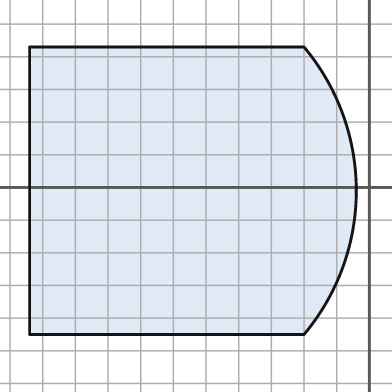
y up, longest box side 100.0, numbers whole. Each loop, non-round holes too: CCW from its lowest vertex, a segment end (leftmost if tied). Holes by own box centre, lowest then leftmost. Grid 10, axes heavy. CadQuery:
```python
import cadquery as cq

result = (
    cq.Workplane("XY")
    .moveTo(-104.0, -45.0)
    .lineTo(-20.0, -45.0)
    .threePointArc((-4.0, -1.0), (-20.0, 43.0))
    .lineTo(-104.0, 43.0)
    .close()
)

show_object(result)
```